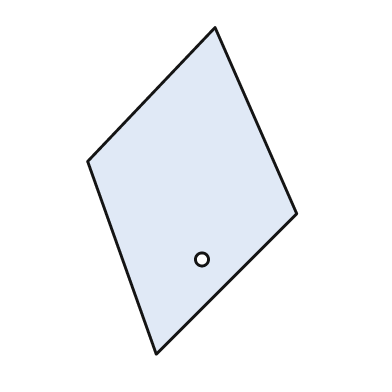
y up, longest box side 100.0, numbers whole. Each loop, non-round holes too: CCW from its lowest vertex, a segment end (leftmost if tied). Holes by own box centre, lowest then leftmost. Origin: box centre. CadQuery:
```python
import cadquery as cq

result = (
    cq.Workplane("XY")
    .moveTo(-11.0, -50.0)
    .lineTo(32.0, -7.0)
    .lineTo(7.0, 50.0)
    .lineTo(-32.0, 9.0)
    .close()
    .moveTo(3.0, -21.0)
    .circle(2.0)
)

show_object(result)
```